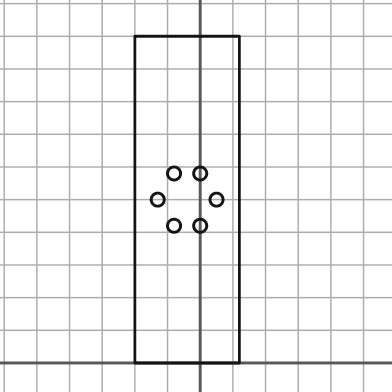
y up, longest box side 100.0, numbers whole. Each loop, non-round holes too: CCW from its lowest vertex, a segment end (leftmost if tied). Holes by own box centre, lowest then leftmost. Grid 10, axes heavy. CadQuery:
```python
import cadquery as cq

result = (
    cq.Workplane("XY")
    .moveTo(-20.0, 0.0)
    .lineTo(12.0, 0.0)
    .lineTo(12.0, 100.0)
    .lineTo(-20.0, 100.0)
    .close()
    .moveTo(-8.0, 42.0)
    .circle(2.0)
    .moveTo(0.0, 42.0)
    .circle(2.0)
    .moveTo(-13.0, 50.0)
    .circle(2.0)
    .moveTo(5.0, 50.0)
    .circle(2.0)
    .moveTo(-8.0, 58.0)
    .circle(2.0)
    .moveTo(0.0, 58.0)
    .circle(2.0)
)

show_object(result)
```